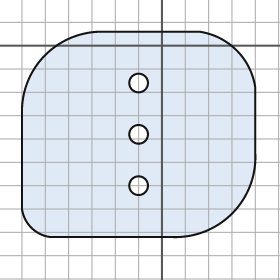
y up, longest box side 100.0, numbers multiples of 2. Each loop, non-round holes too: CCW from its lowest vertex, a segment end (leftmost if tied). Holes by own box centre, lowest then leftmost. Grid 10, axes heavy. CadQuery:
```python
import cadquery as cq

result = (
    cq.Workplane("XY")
    .moveTo(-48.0, -82.0)
    .lineTo(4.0, -82.0)
    .threePointArc((30.0, -72.0), (40.0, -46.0))
    .lineTo(40.0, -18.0)
    .threePointArc((32.0, -2.0), (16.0, 6.0))
    .lineTo(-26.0, 6.0)
    .threePointArc((-50.0, -4.0), (-60.0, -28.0))
    .lineTo(-60.0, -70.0)
    .threePointArc((-56.0, -78.0), (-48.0, -82.0))
    .close()
    .moveTo(-10.0, -60.0)
    .circle(4.0)
    .moveTo(-10.0, -38.0)
    .circle(4.0)
    .moveTo(-10.0, -16.0)
    .circle(4.0)
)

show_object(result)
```